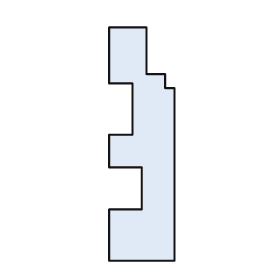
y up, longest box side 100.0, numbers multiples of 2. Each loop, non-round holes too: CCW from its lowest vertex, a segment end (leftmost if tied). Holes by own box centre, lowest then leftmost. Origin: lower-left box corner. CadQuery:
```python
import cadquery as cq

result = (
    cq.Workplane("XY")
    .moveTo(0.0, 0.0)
    .lineTo(28.0, 0.0)
    .lineTo(28.0, 74.0)
    .lineTo(24.0, 74.0)
    .lineTo(24.0, 80.0)
    .lineTo(16.0, 80.0)
    .lineTo(16.0, 100.0)
    .lineTo(0.0, 100.0)
    .lineTo(0.0, 76.0)
    .lineTo(10.0, 76.0)
    .lineTo(10.0, 54.0)
    .lineTo(0.0, 54.0)
    .lineTo(0.0, 40.0)
    .lineTo(14.0, 40.0)
    .lineTo(14.0, 22.0)
    .lineTo(0.0, 22.0)
    .close()
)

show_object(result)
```